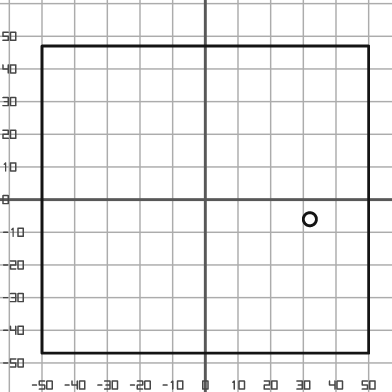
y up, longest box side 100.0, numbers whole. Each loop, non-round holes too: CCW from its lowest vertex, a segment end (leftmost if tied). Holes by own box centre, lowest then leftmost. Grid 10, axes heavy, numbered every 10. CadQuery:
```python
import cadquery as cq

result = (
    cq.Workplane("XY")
    .moveTo(-50.0, -47.0)
    .lineTo(50.0, -47.0)
    .lineTo(50.0, 47.0)
    .lineTo(-50.0, 47.0)
    .close()
    .moveTo(32.0, -6.0)
    .circle(2.0)
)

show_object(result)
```